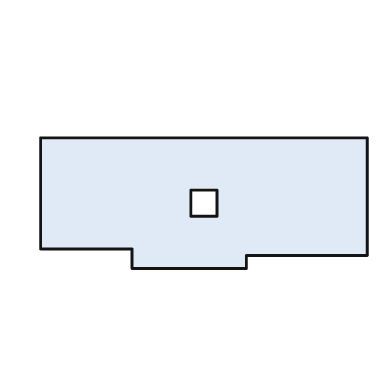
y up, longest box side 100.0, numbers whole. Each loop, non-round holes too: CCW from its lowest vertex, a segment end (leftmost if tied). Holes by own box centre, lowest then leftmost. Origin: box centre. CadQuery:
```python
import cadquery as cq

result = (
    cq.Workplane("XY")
    .moveTo(-22.0, -20.0)
    .lineTo(13.0, -20.0)
    .lineTo(13.0, -16.0)
    .lineTo(50.0, -16.0)
    .lineTo(50.0, 20.0)
    .lineTo(-50.0, 20.0)
    .lineTo(-50.0, -14.0)
    .lineTo(-22.0, -14.0)
    .close()
    .moveTo(-4.0, -4.0)
    .lineTo(4.0, -4.0)
    .lineTo(4.0, 4.0)
    .lineTo(-4.0, 4.0)
    .close()
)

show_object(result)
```